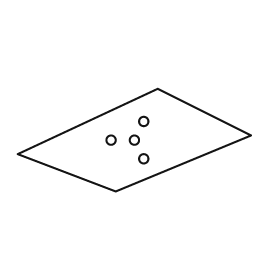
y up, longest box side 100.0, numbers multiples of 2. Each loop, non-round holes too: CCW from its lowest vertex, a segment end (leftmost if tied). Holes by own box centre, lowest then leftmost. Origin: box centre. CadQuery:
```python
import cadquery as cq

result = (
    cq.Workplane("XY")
    .moveTo(-8.0, -22.0)
    .lineTo(50.0, 2.0)
    .lineTo(10.0, 22.0)
    .lineTo(-50.0, -6.0)
    .close()
    .moveTo(4.0, -8.0)
    .circle(2.0)
    .moveTo(-10.0, 0.0)
    .circle(2.0)
    .moveTo(0.0, 0.0)
    .circle(2.0)
    .moveTo(4.0, 8.0)
    .circle(2.0)
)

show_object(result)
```